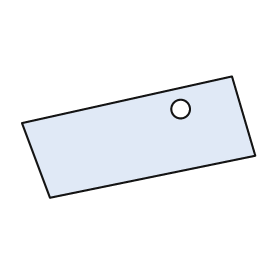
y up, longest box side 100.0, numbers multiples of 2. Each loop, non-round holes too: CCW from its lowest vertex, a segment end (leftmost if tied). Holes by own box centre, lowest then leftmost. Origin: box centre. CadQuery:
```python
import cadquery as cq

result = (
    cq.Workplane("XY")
    .moveTo(-38.0, -26.0)
    .lineTo(50.0, -8.0)
    .lineTo(40.0, 26.0)
    .lineTo(-50.0, 6.0)
    .close()
    .moveTo(18.0, 12.0)
    .circle(4.0)
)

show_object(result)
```